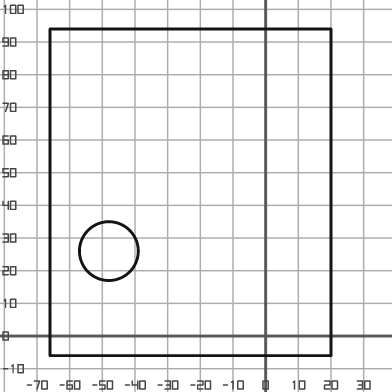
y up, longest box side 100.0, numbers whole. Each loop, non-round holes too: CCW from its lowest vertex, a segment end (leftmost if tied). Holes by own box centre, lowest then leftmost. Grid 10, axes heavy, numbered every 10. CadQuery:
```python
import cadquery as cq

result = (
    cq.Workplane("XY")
    .moveTo(-66.0, -6.0)
    .lineTo(20.0, -6.0)
    .lineTo(20.0, 94.0)
    .lineTo(-66.0, 94.0)
    .close()
    .moveTo(-48.0, 26.0)
    .circle(9.0)
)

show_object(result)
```